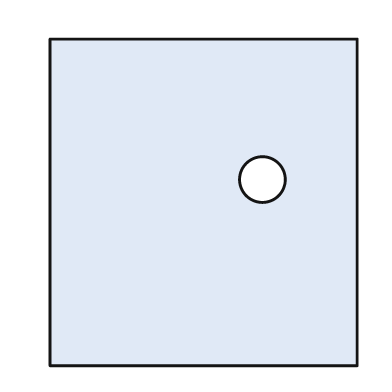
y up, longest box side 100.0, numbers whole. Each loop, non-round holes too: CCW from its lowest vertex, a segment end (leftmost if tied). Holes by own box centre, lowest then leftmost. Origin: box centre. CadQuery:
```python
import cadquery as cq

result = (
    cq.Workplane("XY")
    .moveTo(-47.0, -50.0)
    .lineTo(47.0, -50.0)
    .lineTo(47.0, 50.0)
    .lineTo(-47.0, 50.0)
    .close()
    .moveTo(18.0, 7.0)
    .circle(7.0)
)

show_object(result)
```